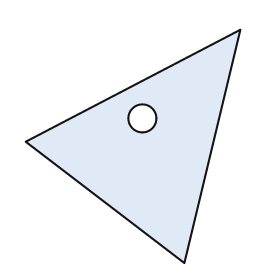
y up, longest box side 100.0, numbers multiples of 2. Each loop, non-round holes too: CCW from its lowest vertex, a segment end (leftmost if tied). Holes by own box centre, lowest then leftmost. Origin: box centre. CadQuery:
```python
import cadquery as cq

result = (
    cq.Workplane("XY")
    .moveTo(22.0, -50.0)
    .lineTo(46.0, 50.0)
    .lineTo(-46.0, 2.0)
    .close()
    .moveTo(4.0, 12.0)
    .circle(6.0)
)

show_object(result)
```